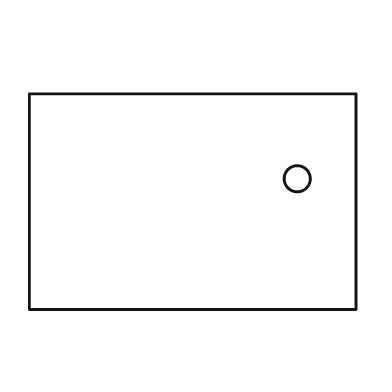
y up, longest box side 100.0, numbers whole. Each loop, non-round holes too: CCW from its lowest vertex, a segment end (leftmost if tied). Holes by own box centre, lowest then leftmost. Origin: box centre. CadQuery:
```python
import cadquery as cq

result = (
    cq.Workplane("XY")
    .moveTo(-50.0, -33.0)
    .lineTo(50.0, -33.0)
    .lineTo(50.0, 33.0)
    .lineTo(-50.0, 33.0)
    .close()
    .moveTo(32.0, 7.0)
    .circle(4.0)
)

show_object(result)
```